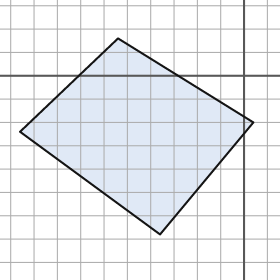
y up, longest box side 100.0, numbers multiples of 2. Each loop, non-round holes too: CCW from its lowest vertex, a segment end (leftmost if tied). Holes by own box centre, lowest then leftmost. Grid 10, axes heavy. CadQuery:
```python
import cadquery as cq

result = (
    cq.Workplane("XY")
    .moveTo(-36.0, -68.0)
    .lineTo(4.0, -20.0)
    .lineTo(-54.0, 16.0)
    .lineTo(-96.0, -24.0)
    .close()
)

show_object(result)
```